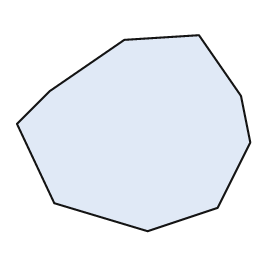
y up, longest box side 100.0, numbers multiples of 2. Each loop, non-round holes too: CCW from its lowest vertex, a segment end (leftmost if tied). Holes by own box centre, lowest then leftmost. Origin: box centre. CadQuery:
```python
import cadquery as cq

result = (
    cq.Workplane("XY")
    .moveTo(6.0, -42.0)
    .lineTo(36.0, -32.0)
    .lineTo(50.0, -4.0)
    .lineTo(46.0, 16.0)
    .lineTo(28.0, 42.0)
    .lineTo(-4.0, 40.0)
    .lineTo(-36.0, 18.0)
    .lineTo(-50.0, 4.0)
    .lineTo(-34.0, -30.0)
    .close()
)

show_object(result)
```